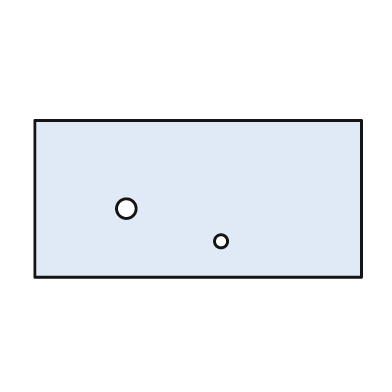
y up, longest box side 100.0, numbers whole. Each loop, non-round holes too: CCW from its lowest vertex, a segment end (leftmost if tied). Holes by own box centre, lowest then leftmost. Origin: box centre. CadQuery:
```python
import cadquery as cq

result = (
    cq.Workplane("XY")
    .moveTo(-50.0, -24.0)
    .lineTo(50.0, -24.0)
    .lineTo(50.0, 24.0)
    .lineTo(-50.0, 24.0)
    .close()
    .moveTo(7.0, -13.0)
    .circle(2.0)
    .moveTo(-22.0, -3.0)
    .circle(3.0)
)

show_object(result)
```